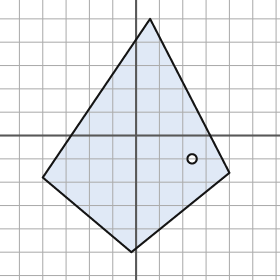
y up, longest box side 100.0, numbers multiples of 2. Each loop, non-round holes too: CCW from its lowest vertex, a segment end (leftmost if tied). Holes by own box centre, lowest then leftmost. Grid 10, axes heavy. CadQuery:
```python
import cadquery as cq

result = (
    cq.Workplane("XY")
    .moveTo(-2.0, -50.0)
    .lineTo(40.0, -16.0)
    .lineTo(6.0, 50.0)
    .lineTo(-40.0, -18.0)
    .close()
    .moveTo(24.0, -10.0)
    .circle(2.0)
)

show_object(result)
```